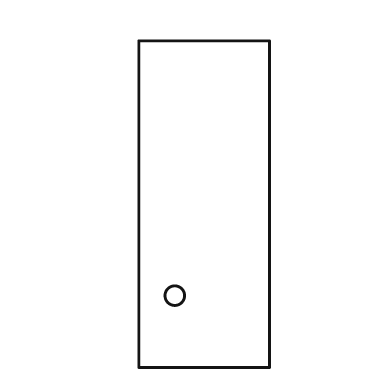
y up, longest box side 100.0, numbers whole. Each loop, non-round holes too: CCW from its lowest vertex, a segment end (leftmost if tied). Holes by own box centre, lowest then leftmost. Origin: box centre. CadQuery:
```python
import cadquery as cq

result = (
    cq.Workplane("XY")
    .moveTo(-20.0, -50.0)
    .lineTo(20.0, -50.0)
    .lineTo(20.0, 50.0)
    .lineTo(-20.0, 50.0)
    .close()
    .moveTo(-9.0, -28.0)
    .circle(3.0)
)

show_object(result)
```